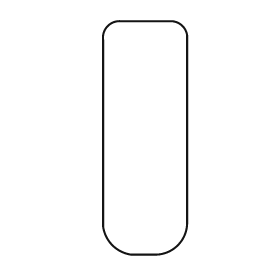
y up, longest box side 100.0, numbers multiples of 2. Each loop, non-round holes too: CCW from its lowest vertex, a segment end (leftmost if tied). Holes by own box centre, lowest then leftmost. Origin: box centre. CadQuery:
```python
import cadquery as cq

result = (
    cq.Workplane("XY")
    .moveTo(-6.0, -50.0)
    .lineTo(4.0, -50.0)
    .threePointArc((14.0, -46.0), (18.0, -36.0))
    .lineTo(18.0, 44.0)
    .threePointArc((16.0, 48.0), (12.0, 50.0))
    .lineTo(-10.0, 50.0)
    .threePointArc((-16.0, 48.0), (-18.0, 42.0))
    .lineTo(-18.0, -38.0)
    .threePointArc((-14.0, -46.0), (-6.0, -50.0))
    .close()
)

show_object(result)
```